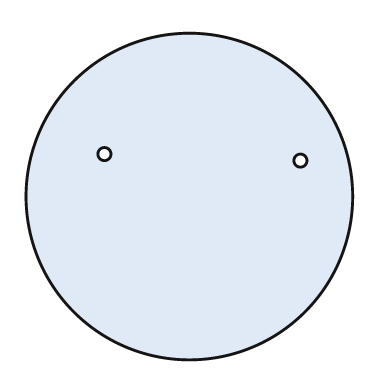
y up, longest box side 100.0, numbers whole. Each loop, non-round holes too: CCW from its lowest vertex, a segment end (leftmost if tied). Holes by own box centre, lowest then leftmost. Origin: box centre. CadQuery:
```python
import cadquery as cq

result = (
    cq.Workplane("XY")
    .moveTo(0.0, 0.0)
    .circle(50.0)
    .moveTo(34.0, 11.0)
    .circle(2.0)
    .moveTo(-26.0, 13.0)
    .circle(2.0)
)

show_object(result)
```